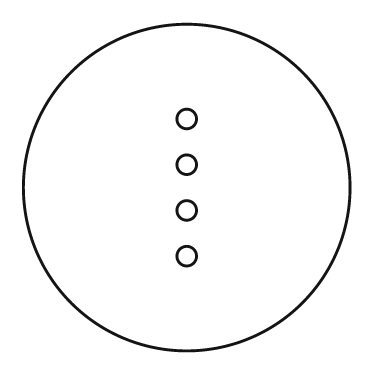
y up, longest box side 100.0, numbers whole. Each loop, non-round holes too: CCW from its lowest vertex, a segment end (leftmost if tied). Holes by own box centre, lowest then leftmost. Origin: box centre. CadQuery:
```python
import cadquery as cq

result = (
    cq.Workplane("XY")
    .moveTo(0.0, 0.0)
    .circle(50.0)
    .moveTo(0.0, -21.0)
    .circle(3.0)
    .moveTo(0.0, -7.0)
    .circle(3.0)
    .moveTo(0.0, 7.0)
    .circle(3.0)
    .moveTo(0.0, 21.0)
    .circle(3.0)
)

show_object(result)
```